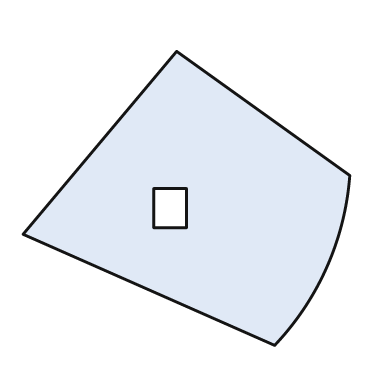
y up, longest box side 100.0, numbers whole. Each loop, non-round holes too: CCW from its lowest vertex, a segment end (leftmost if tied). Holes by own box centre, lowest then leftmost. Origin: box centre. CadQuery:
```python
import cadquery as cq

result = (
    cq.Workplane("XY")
    .moveTo(27.0, -45.0)
    .threePointArc((43.0, -21.0), (50.0, 7.0))
    .lineTo(-3.0, 45.0)
    .lineTo(-50.0, -11.0)
    .close()
    .moveTo(-10.0, -9.0)
    .lineTo(0.0, -9.0)
    .lineTo(0.0, 3.0)
    .lineTo(-10.0, 3.0)
    .close()
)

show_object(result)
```